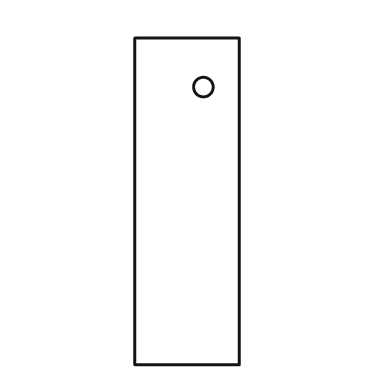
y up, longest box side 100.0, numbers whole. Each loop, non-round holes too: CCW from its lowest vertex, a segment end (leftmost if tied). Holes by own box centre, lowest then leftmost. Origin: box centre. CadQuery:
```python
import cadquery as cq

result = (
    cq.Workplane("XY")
    .moveTo(-16.0, -50.0)
    .lineTo(16.0, -50.0)
    .lineTo(16.0, 50.0)
    .lineTo(-16.0, 50.0)
    .close()
    .moveTo(5.0, 35.0)
    .circle(3.0)
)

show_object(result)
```